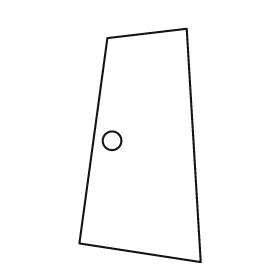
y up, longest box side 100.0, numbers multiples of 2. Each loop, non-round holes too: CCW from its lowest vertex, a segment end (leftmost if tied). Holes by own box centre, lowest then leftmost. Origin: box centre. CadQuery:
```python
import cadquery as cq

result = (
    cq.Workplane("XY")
    .moveTo(26.0, -50.0)
    .lineTo(20.0, 50.0)
    .lineTo(-14.0, 46.0)
    .lineTo(-26.0, -42.0)
    .close()
    .moveTo(-12.0, 2.0)
    .circle(4.0)
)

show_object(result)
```